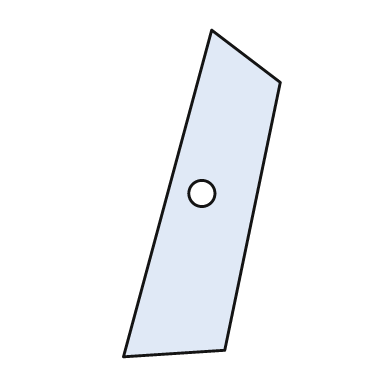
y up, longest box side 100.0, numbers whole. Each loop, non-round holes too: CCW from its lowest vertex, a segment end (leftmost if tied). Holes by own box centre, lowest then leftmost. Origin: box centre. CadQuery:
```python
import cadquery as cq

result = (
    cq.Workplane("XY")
    .moveTo(-24.0, -50.0)
    .lineTo(7.0, -48.0)
    .lineTo(24.0, 34.0)
    .lineTo(3.0, 50.0)
    .close()
    .moveTo(0.0, 0.0)
    .circle(4.0)
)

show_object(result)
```